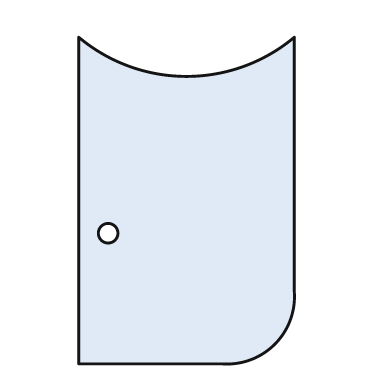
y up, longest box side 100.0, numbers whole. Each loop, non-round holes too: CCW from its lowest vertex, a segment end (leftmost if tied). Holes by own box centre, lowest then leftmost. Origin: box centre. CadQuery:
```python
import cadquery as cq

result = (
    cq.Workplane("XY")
    .moveTo(-33.0, -50.0)
    .lineTo(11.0, -50.0)
    .threePointArc((27.0, -44.0), (33.0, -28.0))
    .lineTo(33.0, 50.0)
    .threePointArc((0.0, 38.0), (-33.0, 50.0))
    .close()
    .moveTo(-24.0, -10.0)
    .circle(3.0)
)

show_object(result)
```